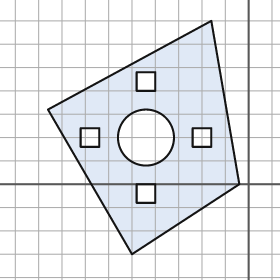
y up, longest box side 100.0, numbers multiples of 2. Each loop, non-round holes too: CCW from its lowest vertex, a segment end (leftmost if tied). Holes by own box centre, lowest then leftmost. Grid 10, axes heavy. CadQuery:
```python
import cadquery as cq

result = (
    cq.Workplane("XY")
    .moveTo(-50.0, -30.0)
    .lineTo(-4.0, 0.0)
    .lineTo(-16.0, 70.0)
    .lineTo(-86.0, 32.0)
    .close()
    .moveTo(-48.0, -8.0)
    .lineTo(-40.0, -8.0)
    .lineTo(-40.0, 0.0)
    .lineTo(-48.0, 0.0)
    .close()
    .moveTo(-72.0, 16.0)
    .lineTo(-64.0, 16.0)
    .lineTo(-64.0, 24.0)
    .lineTo(-72.0, 24.0)
    .close()
    .moveTo(-44.0, 20.0)
    .circle(12.0)
    .moveTo(-24.0, 16.0)
    .lineTo(-16.0, 16.0)
    .lineTo(-16.0, 24.0)
    .lineTo(-24.0, 24.0)
    .close()
    .moveTo(-48.0, 40.0)
    .lineTo(-40.0, 40.0)
    .lineTo(-40.0, 48.0)
    .lineTo(-48.0, 48.0)
    .close()
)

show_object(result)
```